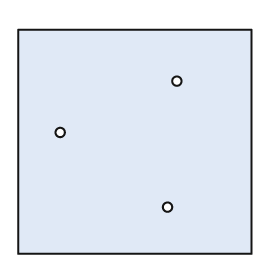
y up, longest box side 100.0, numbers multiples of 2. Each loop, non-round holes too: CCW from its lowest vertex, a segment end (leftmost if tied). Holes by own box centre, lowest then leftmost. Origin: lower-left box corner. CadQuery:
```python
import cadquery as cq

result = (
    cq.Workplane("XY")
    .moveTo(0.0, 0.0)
    .lineTo(100.0, 0.0)
    .lineTo(100.0, 96.0)
    .lineTo(0.0, 96.0)
    .close()
    .moveTo(64.0, 20.0)
    .circle(2.0)
    .moveTo(18.0, 52.0)
    .circle(2.0)
    .moveTo(68.0, 74.0)
    .circle(2.0)
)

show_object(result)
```